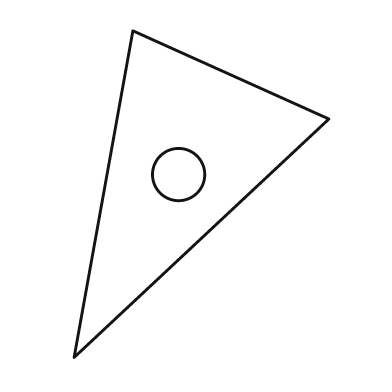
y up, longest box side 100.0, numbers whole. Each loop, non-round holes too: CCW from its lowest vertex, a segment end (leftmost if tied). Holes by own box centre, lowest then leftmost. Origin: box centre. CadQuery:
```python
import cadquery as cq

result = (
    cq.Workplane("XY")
    .moveTo(-39.0, -50.0)
    .lineTo(39.0, 23.0)
    .lineTo(-21.0, 50.0)
    .close()
    .moveTo(-7.0, 6.0)
    .circle(8.0)
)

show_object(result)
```